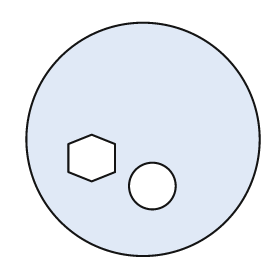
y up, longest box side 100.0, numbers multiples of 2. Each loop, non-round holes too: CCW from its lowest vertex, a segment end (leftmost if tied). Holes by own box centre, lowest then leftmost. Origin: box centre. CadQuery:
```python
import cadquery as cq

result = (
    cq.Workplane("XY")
    .moveTo(0.0, 0.0)
    .circle(50.0)
    .moveTo(4.0, -20.0)
    .circle(10.0)
    .moveTo(-22.0, -18.0)
    .lineTo(-12.0, -14.0)
    .lineTo(-12.0, -2.0)
    .lineTo(-22.0, 2.0)
    .lineTo(-32.0, -2.0)
    .lineTo(-32.0, -14.0)
    .close()
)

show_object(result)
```